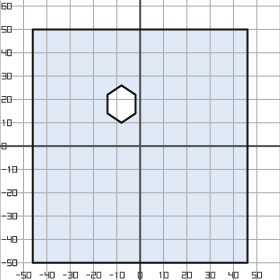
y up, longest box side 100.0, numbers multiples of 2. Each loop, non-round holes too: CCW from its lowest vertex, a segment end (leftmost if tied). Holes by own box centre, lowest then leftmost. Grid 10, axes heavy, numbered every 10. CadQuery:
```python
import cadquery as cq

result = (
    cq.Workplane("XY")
    .moveTo(-46.0, -50.0)
    .lineTo(46.0, -50.0)
    .lineTo(46.0, 50.0)
    .lineTo(-46.0, 50.0)
    .close()
    .moveTo(-8.0, 10.0)
    .lineTo(-2.0, 14.0)
    .lineTo(-2.0, 22.0)
    .lineTo(-8.0, 26.0)
    .lineTo(-14.0, 22.0)
    .lineTo(-14.0, 14.0)
    .close()
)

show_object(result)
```